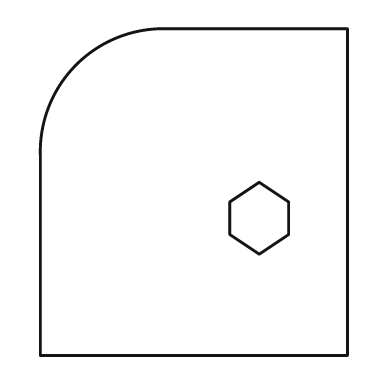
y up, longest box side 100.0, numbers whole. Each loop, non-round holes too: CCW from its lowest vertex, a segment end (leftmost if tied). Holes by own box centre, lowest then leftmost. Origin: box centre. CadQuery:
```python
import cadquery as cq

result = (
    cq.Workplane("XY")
    .moveTo(-47.0, -50.0)
    .lineTo(47.0, -50.0)
    .lineTo(47.0, 50.0)
    .lineTo(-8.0, 50.0)
    .threePointArc((-36.0, 39.0), (-47.0, 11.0))
    .close()
    .moveTo(20.0, -19.0)
    .lineTo(29.0, -13.0)
    .lineTo(29.0, -3.0)
    .lineTo(20.0, 3.0)
    .lineTo(11.0, -3.0)
    .lineTo(11.0, -13.0)
    .close()
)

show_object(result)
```